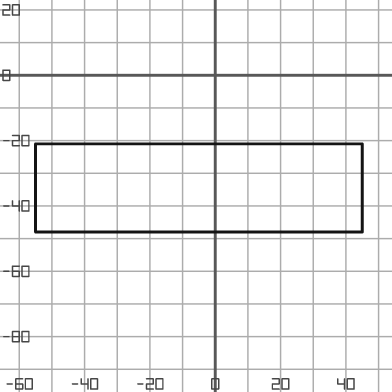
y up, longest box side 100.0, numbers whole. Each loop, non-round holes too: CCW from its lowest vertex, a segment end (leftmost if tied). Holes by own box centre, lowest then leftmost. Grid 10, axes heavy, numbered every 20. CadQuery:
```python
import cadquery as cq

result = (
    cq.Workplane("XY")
    .moveTo(-55.0, -48.0)
    .lineTo(45.0, -48.0)
    .lineTo(45.0, -21.0)
    .lineTo(-55.0, -21.0)
    .close()
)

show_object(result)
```